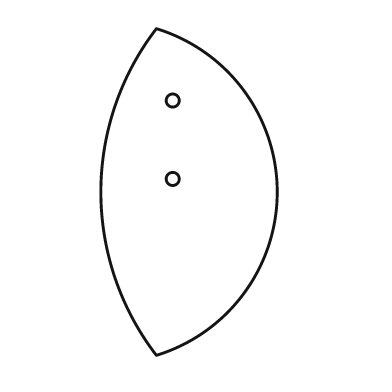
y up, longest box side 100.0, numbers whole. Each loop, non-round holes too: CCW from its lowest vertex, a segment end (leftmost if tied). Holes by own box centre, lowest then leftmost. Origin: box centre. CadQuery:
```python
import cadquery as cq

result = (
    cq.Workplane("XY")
    .moveTo(-10.0, -50.0)
    .threePointArc((27.0, 0.0), (-10.0, 50.0))
    .threePointArc((-27.0, 0.0), (-10.0, -50.0))
    .close()
    .moveTo(-5.0, 4.0)
    .circle(2.0)
    .moveTo(-5.0, 28.0)
    .circle(2.0)
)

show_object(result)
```